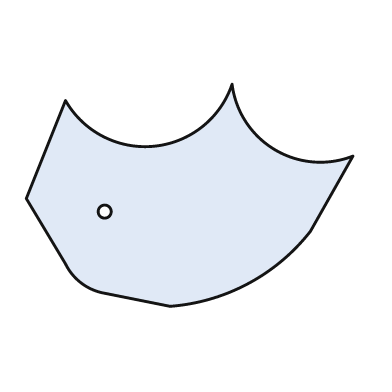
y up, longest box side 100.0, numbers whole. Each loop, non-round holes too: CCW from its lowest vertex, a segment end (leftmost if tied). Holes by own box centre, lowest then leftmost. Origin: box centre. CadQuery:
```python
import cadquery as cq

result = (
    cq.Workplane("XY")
    .moveTo(-6.0, -34.0)
    .threePointArc((18.0, -27.0), (37.0, -11.0))
    .lineTo(50.0, 12.0)
    .threePointArc((26.0, 14.0), (13.0, 34.0))
    .threePointArc((-11.0, 15.0), (-38.0, 29.0))
    .lineTo(-50.0, -1.0)
    .lineTo(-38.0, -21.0)
    .threePointArc((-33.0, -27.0), (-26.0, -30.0))
    .close()
    .moveTo(-26.0, -5.0)
    .circle(2.0)
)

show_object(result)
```